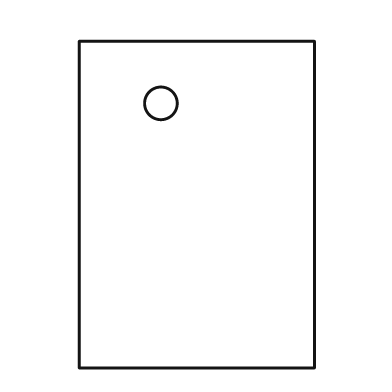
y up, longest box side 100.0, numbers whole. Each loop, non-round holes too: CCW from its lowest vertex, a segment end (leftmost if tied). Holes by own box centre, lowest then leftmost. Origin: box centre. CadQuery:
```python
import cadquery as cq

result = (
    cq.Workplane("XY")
    .moveTo(-36.0, -50.0)
    .lineTo(36.0, -50.0)
    .lineTo(36.0, 50.0)
    .lineTo(-36.0, 50.0)
    .close()
    .moveTo(-11.0, 31.0)
    .circle(5.0)
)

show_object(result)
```